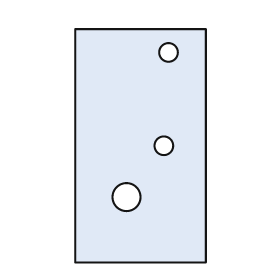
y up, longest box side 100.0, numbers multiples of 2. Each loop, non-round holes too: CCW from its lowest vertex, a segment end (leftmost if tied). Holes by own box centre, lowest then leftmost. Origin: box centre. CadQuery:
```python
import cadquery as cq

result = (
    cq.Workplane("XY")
    .moveTo(-28.0, -50.0)
    .lineTo(28.0, -50.0)
    .lineTo(28.0, 50.0)
    .lineTo(-28.0, 50.0)
    .close()
    .moveTo(-6.0, -22.0)
    .circle(6.0)
    .moveTo(10.0, 0.0)
    .circle(4.0)
    .moveTo(12.0, 40.0)
    .circle(4.0)
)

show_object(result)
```